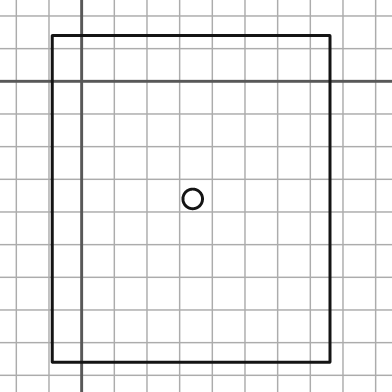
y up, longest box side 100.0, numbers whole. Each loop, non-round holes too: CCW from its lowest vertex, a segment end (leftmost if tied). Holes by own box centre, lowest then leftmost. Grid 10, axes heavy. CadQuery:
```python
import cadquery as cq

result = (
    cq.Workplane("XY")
    .moveTo(-9.0, -86.0)
    .lineTo(76.0, -86.0)
    .lineTo(76.0, 14.0)
    .lineTo(-9.0, 14.0)
    .close()
    .moveTo(34.0, -36.0)
    .circle(3.0)
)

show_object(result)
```